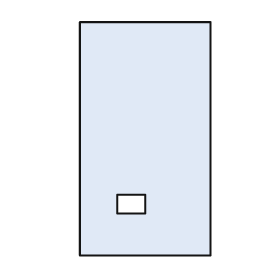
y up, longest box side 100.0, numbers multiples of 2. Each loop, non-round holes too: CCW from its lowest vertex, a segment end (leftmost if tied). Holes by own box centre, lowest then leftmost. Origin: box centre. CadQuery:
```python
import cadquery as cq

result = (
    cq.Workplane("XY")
    .moveTo(-28.0, -50.0)
    .lineTo(28.0, -50.0)
    .lineTo(28.0, 50.0)
    .lineTo(-28.0, 50.0)
    .close()
    .moveTo(-12.0, -32.0)
    .lineTo(0.0, -32.0)
    .lineTo(0.0, -24.0)
    .lineTo(-12.0, -24.0)
    .close()
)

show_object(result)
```